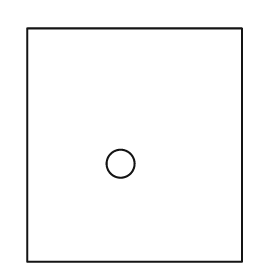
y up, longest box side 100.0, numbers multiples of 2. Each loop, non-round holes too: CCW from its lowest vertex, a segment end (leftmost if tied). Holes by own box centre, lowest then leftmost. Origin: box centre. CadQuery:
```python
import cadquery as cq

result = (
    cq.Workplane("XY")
    .moveTo(-46.0, -50.0)
    .lineTo(46.0, -50.0)
    .lineTo(46.0, 50.0)
    .lineTo(-46.0, 50.0)
    .close()
    .moveTo(-6.0, -8.0)
    .circle(6.0)
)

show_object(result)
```